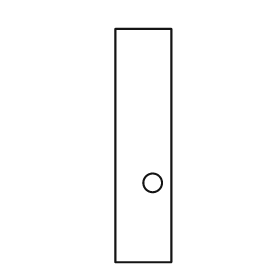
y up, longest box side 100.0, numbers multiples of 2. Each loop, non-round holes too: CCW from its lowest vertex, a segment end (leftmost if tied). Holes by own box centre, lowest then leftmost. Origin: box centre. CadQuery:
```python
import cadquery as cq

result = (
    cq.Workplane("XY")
    .moveTo(-12.0, -50.0)
    .lineTo(12.0, -50.0)
    .lineTo(12.0, 50.0)
    .lineTo(-12.0, 50.0)
    .close()
    .moveTo(4.0, -16.0)
    .circle(4.0)
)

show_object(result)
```